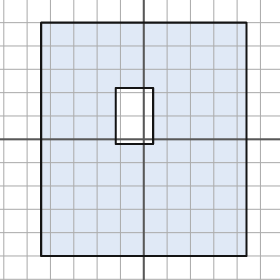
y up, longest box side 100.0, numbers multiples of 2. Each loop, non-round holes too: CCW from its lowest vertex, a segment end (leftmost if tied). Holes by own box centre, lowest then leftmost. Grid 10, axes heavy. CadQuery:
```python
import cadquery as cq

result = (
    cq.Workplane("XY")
    .moveTo(-44.0, -50.0)
    .lineTo(44.0, -50.0)
    .lineTo(44.0, 50.0)
    .lineTo(-44.0, 50.0)
    .close()
    .moveTo(-12.0, -2.0)
    .lineTo(4.0, -2.0)
    .lineTo(4.0, 22.0)
    .lineTo(-12.0, 22.0)
    .close()
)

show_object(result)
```